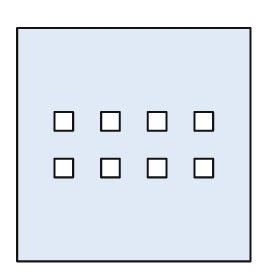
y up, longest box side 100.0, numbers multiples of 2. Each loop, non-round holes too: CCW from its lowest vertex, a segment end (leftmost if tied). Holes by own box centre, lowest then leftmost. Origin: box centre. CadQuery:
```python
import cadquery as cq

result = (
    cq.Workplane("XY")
    .moveTo(-50.0, -50.0)
    .lineTo(50.0, -50.0)
    .lineTo(50.0, 50.0)
    .lineTo(-50.0, 50.0)
    .close()
    .moveTo(-34.0, -14.0)
    .lineTo(-26.0, -14.0)
    .lineTo(-26.0, -6.0)
    .lineTo(-34.0, -6.0)
    .close()
    .moveTo(-14.0, -14.0)
    .lineTo(-6.0, -14.0)
    .lineTo(-6.0, -6.0)
    .lineTo(-14.0, -6.0)
    .close()
    .moveTo(6.0, -14.0)
    .lineTo(14.0, -14.0)
    .lineTo(14.0, -6.0)
    .lineTo(6.0, -6.0)
    .close()
    .moveTo(26.0, -14.0)
    .lineTo(34.0, -14.0)
    .lineTo(34.0, -6.0)
    .lineTo(26.0, -6.0)
    .close()
    .moveTo(-34.0, 6.0)
    .lineTo(-26.0, 6.0)
    .lineTo(-26.0, 14.0)
    .lineTo(-34.0, 14.0)
    .close()
    .moveTo(-14.0, 6.0)
    .lineTo(-6.0, 6.0)
    .lineTo(-6.0, 14.0)
    .lineTo(-14.0, 14.0)
    .close()
    .moveTo(6.0, 6.0)
    .lineTo(14.0, 6.0)
    .lineTo(14.0, 14.0)
    .lineTo(6.0, 14.0)
    .close()
    .moveTo(26.0, 6.0)
    .lineTo(34.0, 6.0)
    .lineTo(34.0, 14.0)
    .lineTo(26.0, 14.0)
    .close()
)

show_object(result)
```